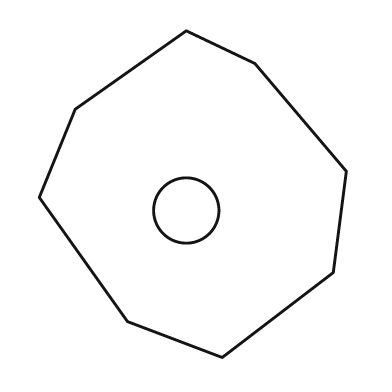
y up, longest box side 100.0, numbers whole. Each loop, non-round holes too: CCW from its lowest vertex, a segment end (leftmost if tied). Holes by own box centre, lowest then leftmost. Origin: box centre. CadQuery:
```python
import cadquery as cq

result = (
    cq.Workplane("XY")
    .moveTo(9.0, -50.0)
    .lineTo(43.0, -24.0)
    .lineTo(47.0, 7.0)
    .lineTo(19.0, 40.0)
    .lineTo(-2.0, 50.0)
    .lineTo(-36.0, 26.0)
    .lineTo(-47.0, -1.0)
    .lineTo(-20.0, -39.0)
    .close()
    .moveTo(-2.0, -5.0)
    .circle(10.0)
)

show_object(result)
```